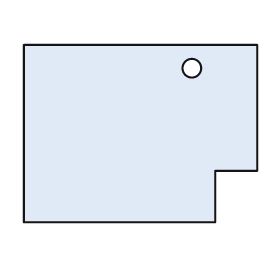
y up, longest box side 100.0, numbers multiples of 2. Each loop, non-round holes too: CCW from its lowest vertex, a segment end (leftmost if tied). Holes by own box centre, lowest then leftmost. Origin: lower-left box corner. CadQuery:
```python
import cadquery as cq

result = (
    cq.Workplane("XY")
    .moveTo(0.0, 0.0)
    .lineTo(82.0, 0.0)
    .lineTo(82.0, 22.0)
    .lineTo(100.0, 22.0)
    .lineTo(100.0, 76.0)
    .lineTo(0.0, 76.0)
    .close()
    .moveTo(72.0, 66.0)
    .circle(4.0)
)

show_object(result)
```